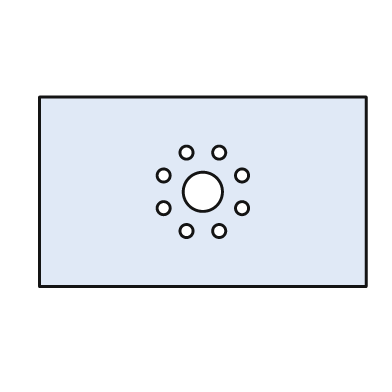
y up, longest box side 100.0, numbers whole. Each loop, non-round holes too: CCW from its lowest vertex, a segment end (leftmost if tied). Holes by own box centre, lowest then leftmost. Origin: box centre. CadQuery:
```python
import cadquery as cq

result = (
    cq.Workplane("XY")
    .moveTo(-50.0, -29.0)
    .lineTo(50.0, -29.0)
    .lineTo(50.0, 29.0)
    .lineTo(-50.0, 29.0)
    .close()
    .moveTo(-5.0, -12.0)
    .circle(2.0)
    .moveTo(5.0, -12.0)
    .circle(2.0)
    .moveTo(-12.0, -5.0)
    .circle(2.0)
    .moveTo(12.0, -5.0)
    .circle(2.0)
    .moveTo(0.0, 0.0)
    .circle(6.0)
    .moveTo(-12.0, 5.0)
    .circle(2.0)
    .moveTo(12.0, 5.0)
    .circle(2.0)
    .moveTo(-5.0, 12.0)
    .circle(2.0)
    .moveTo(5.0, 12.0)
    .circle(2.0)
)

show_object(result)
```